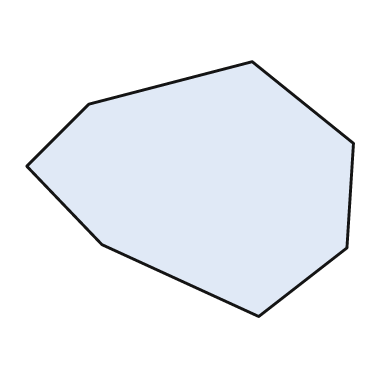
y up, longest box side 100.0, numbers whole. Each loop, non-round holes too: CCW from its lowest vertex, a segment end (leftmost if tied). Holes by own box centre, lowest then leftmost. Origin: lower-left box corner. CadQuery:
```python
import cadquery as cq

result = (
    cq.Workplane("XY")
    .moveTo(71.0, 0.0)
    .lineTo(98.0, 21.0)
    .lineTo(100.0, 53.0)
    .lineTo(69.0, 78.0)
    .lineTo(19.0, 65.0)
    .lineTo(0.0, 46.0)
    .lineTo(23.0, 22.0)
    .close()
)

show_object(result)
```